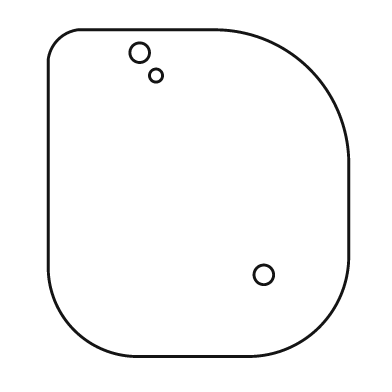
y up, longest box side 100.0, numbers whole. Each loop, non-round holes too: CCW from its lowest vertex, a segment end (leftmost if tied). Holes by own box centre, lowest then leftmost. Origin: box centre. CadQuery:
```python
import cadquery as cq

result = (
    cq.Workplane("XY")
    .moveTo(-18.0, -50.0)
    .lineTo(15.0, -50.0)
    .threePointArc((37.0, -41.0), (46.0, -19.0))
    .lineTo(46.0, 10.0)
    .threePointArc((34.0, 38.0), (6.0, 50.0))
    .lineTo(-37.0, 50.0)
    .threePointArc((-43.0, 47.0), (-46.0, 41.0))
    .lineTo(-46.0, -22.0)
    .threePointArc((-38.0, -42.0), (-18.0, -50.0))
    .close()
    .moveTo(20.0, -25.0)
    .circle(3.0)
    .moveTo(-13.0, 36.0)
    .circle(2.0)
    .moveTo(-18.0, 43.0)
    .circle(3.0)
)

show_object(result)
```